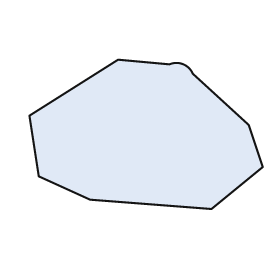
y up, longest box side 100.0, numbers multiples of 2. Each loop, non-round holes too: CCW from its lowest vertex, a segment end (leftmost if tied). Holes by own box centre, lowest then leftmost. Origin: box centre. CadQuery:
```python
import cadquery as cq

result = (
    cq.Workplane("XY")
    .moveTo(28.0, -32.0)
    .lineTo(50.0, -14.0)
    .lineTo(44.0, 4.0)
    .lineTo(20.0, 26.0)
    .threePointArc((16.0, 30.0), (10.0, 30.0))
    .lineTo(-12.0, 32.0)
    .lineTo(-50.0, 8.0)
    .lineTo(-46.0, -18.0)
    .lineTo(-24.0, -28.0)
    .close()
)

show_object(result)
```